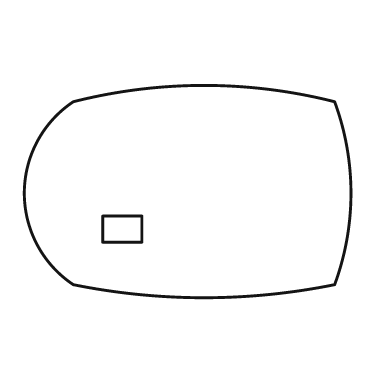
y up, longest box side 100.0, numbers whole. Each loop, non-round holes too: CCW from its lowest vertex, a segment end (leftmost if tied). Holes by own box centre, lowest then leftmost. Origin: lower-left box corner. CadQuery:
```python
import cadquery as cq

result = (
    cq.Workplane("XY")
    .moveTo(15.0, 4.0)
    .threePointArc((55.0, 0.0), (95.0, 4.0))
    .threePointArc((100.0, 32.0), (95.0, 60.0))
    .threePointArc((55.0, 65.0), (15.0, 60.0))
    .threePointArc((0.0, 32.0), (15.0, 4.0))
    .close()
    .moveTo(24.0, 17.0)
    .lineTo(36.0, 17.0)
    .lineTo(36.0, 25.0)
    .lineTo(24.0, 25.0)
    .close()
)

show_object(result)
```